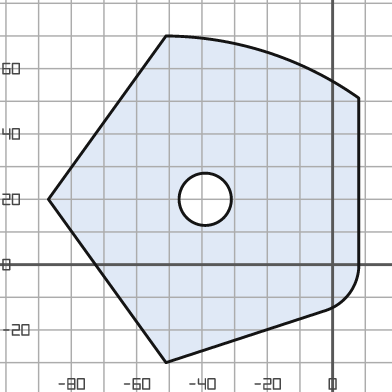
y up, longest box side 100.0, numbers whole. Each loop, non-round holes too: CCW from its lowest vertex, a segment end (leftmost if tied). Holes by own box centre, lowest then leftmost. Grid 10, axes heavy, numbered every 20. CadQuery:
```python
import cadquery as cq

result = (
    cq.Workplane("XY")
    .moveTo(-51.0, -30.0)
    .lineTo(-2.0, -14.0)
    .threePointArc((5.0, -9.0), (8.0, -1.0))
    .lineTo(8.0, 51.0)
    .threePointArc((-20.0, 65.0), (-51.0, 70.0))
    .lineTo(-87.0, 20.0)
    .close()
    .moveTo(-39.0, 20.0)
    .circle(8.0)
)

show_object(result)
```